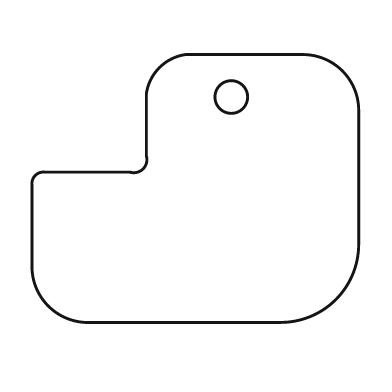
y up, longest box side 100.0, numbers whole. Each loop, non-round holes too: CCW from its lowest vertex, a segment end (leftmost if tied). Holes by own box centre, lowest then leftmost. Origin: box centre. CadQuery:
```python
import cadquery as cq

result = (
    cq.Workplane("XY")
    .moveTo(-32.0, -41.0)
    .lineTo(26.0, -41.0)
    .threePointArc((43.0, -34.0), (50.0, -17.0))
    .lineTo(50.0, 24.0)
    .threePointArc((45.0, 36.0), (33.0, 41.0))
    .lineTo(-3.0, 41.0)
    .threePointArc((-11.0, 37.0), (-15.0, 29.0))
    .lineTo(-15.0, 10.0)
    .threePointArc((-16.0, 6.0), (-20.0, 5.0))
    .lineTo(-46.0, 5.0)
    .threePointArc((-49.0, 4.0), (-50.0, 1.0))
    .lineTo(-50.0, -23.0)
    .threePointArc((-45.0, -36.0), (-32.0, -41.0))
    .close()
    .moveTo(11.0, 28.0)
    .circle(5.0)
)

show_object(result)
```